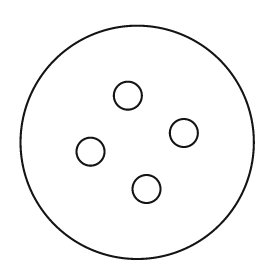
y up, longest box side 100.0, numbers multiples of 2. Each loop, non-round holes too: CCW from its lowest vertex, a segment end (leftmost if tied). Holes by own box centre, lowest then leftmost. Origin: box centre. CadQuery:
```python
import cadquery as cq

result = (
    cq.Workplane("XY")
    .moveTo(0.0, 0.0)
    .circle(50.0)
    .moveTo(4.0, -20.0)
    .circle(6.0)
    .moveTo(-20.0, -4.0)
    .circle(6.0)
    .moveTo(20.0, 4.0)
    .circle(6.0)
    .moveTo(-4.0, 20.0)
    .circle(6.0)
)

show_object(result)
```